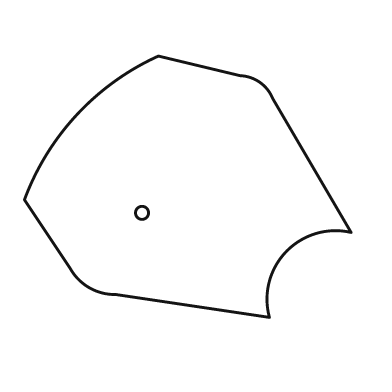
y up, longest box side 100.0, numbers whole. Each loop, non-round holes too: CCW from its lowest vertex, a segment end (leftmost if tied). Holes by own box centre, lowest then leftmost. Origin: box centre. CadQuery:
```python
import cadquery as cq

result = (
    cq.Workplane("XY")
    .moveTo(25.0, -40.0)
    .threePointArc((30.0, -20.0), (50.0, -14.0))
    .lineTo(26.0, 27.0)
    .threePointArc((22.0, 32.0), (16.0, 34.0))
    .lineTo(-9.0, 40.0)
    .threePointArc((-34.0, 22.0), (-50.0, -4.0))
    .lineTo(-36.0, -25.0)
    .threePointArc((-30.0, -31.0), (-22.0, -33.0))
    .close()
    .moveTo(-14.0, -8.0)
    .circle(2.0)
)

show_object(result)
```